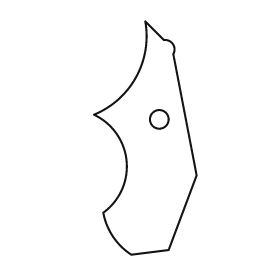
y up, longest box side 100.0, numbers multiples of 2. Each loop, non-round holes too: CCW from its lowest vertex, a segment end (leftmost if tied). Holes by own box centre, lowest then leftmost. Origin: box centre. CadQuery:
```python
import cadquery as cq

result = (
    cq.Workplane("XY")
    .moveTo(-6.0, -50.0)
    .lineTo(10.0, -48.0)
    .lineTo(22.0, -16.0)
    .lineTo(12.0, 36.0)
    .threePointArc((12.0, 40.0), (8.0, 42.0))
    .lineTo(0.0, 50.0)
    .threePointArc((-4.0, 26.0), (-22.0, 10.0))
    .threePointArc((-8.0, -10.0), (-18.0, -32.0))
    .threePointArc((-14.0, -42.0), (-6.0, -50.0))
    .close()
    .moveTo(6.0, 8.0)
    .circle(4.0)
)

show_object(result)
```